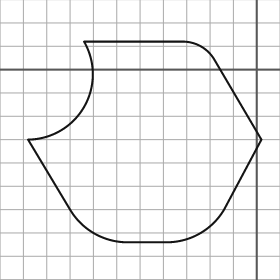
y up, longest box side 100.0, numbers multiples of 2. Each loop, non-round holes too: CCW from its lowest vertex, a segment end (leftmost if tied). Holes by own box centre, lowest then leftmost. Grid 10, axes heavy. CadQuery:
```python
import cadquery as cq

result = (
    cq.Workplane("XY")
    .moveTo(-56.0, -74.0)
    .lineTo(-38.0, -74.0)
    .threePointArc((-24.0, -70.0), (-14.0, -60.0))
    .lineTo(2.0, -30.0)
    .lineTo(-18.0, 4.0)
    .threePointArc((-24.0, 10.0), (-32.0, 12.0))
    .lineTo(-74.0, 12.0)
    .threePointArc((-74.0, -16.0), (-98.0, -30.0))
    .lineTo(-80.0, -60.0)
    .threePointArc((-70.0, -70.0), (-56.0, -74.0))
    .close()
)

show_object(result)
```